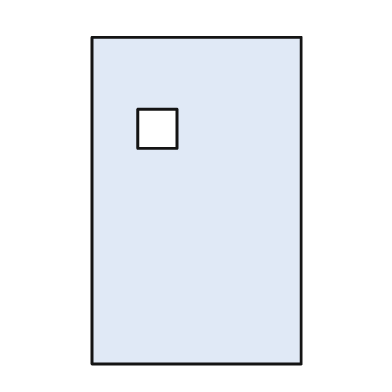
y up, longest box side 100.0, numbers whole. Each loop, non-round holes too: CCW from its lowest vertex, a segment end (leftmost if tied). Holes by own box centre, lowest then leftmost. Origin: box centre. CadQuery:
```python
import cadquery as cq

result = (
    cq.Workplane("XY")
    .moveTo(-32.0, -50.0)
    .lineTo(32.0, -50.0)
    .lineTo(32.0, 50.0)
    .lineTo(-32.0, 50.0)
    .close()
    .moveTo(-18.0, 16.0)
    .lineTo(-6.0, 16.0)
    .lineTo(-6.0, 28.0)
    .lineTo(-18.0, 28.0)
    .close()
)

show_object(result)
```